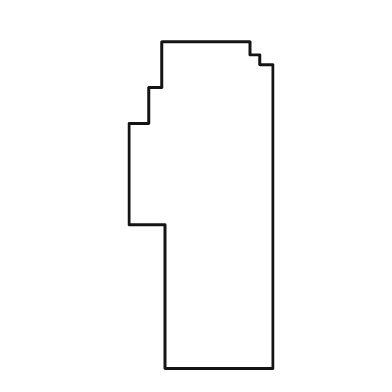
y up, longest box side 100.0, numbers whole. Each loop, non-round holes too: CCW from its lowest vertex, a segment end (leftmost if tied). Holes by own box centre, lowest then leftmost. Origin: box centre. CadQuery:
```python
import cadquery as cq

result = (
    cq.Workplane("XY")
    .moveTo(-11.0, -50.0)
    .lineTo(22.0, -50.0)
    .lineTo(22.0, 43.0)
    .lineTo(18.0, 43.0)
    .lineTo(18.0, 46.0)
    .lineTo(15.0, 46.0)
    .lineTo(15.0, 50.0)
    .lineTo(-12.0, 50.0)
    .lineTo(-12.0, 36.0)
    .lineTo(-16.0, 36.0)
    .lineTo(-16.0, 25.0)
    .lineTo(-22.0, 25.0)
    .lineTo(-22.0, -6.0)
    .lineTo(-11.0, -6.0)
    .close()
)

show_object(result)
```